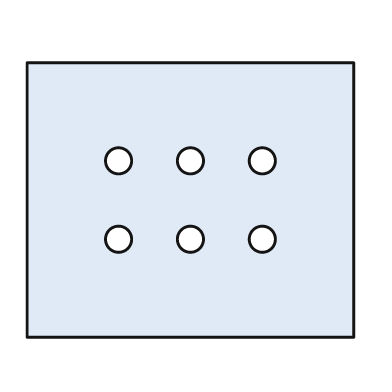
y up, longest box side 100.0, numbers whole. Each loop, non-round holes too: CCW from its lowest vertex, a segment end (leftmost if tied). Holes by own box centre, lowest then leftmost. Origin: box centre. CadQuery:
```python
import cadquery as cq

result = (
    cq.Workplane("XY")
    .moveTo(-50.0, -42.0)
    .lineTo(50.0, -42.0)
    .lineTo(50.0, 42.0)
    .lineTo(-50.0, 42.0)
    .close()
    .moveTo(-22.0, -12.0)
    .circle(4.0)
    .moveTo(0.0, -12.0)
    .circle(4.0)
    .moveTo(22.0, -12.0)
    .circle(4.0)
    .moveTo(-22.0, 12.0)
    .circle(4.0)
    .moveTo(0.0, 12.0)
    .circle(4.0)
    .moveTo(22.0, 12.0)
    .circle(4.0)
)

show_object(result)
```